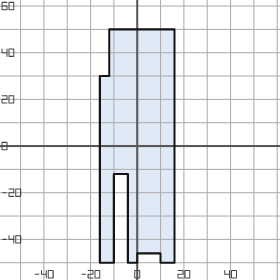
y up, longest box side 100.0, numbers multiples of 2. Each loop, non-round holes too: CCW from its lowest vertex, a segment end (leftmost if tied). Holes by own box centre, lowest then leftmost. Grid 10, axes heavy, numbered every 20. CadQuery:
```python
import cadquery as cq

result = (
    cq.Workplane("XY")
    .moveTo(-16.0, -50.0)
    .lineTo(-10.0, -50.0)
    .lineTo(-10.0, -12.0)
    .lineTo(-4.0, -12.0)
    .lineTo(-4.0, -50.0)
    .lineTo(0.0, -50.0)
    .lineTo(0.0, -46.0)
    .lineTo(10.0, -46.0)
    .lineTo(10.0, -50.0)
    .lineTo(16.0, -50.0)
    .lineTo(16.0, 50.0)
    .lineTo(-12.0, 50.0)
    .lineTo(-12.0, 30.0)
    .lineTo(-16.0, 30.0)
    .close()
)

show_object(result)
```